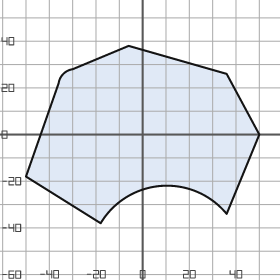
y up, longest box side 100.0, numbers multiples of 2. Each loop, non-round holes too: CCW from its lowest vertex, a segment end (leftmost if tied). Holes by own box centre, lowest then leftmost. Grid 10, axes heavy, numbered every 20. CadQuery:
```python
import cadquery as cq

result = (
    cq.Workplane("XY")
    .moveTo(-18.0, -38.0)
    .threePointArc((8.0, -22.0), (36.0, -34.0))
    .lineTo(50.0, 0.0)
    .lineTo(36.0, 26.0)
    .lineTo(-6.0, 38.0)
    .lineTo(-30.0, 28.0)
    .threePointArc((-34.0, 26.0), (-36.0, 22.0))
    .lineTo(-50.0, -18.0)
    .close()
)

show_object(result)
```